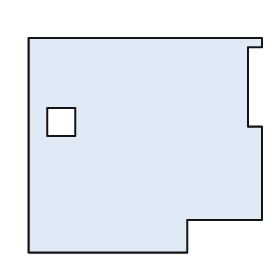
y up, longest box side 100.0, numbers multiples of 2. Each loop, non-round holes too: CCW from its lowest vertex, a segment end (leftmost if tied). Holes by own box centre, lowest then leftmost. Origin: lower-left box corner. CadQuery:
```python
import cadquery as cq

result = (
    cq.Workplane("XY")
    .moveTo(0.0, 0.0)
    .lineTo(68.0, 0.0)
    .lineTo(68.0, 14.0)
    .lineTo(100.0, 14.0)
    .lineTo(100.0, 54.0)
    .lineTo(94.0, 54.0)
    .lineTo(94.0, 88.0)
    .lineTo(100.0, 88.0)
    .lineTo(100.0, 92.0)
    .lineTo(0.0, 92.0)
    .close()
    .moveTo(8.0, 50.0)
    .lineTo(20.0, 50.0)
    .lineTo(20.0, 62.0)
    .lineTo(8.0, 62.0)
    .close()
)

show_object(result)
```